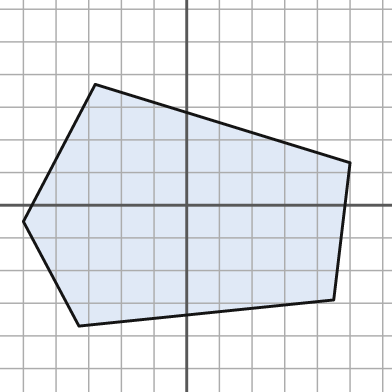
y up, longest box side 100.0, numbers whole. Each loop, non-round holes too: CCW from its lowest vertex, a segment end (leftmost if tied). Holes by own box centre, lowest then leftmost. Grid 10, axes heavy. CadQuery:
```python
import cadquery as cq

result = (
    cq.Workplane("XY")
    .moveTo(-33.0, -37.0)
    .lineTo(45.0, -29.0)
    .lineTo(50.0, 13.0)
    .lineTo(-28.0, 37.0)
    .lineTo(-50.0, -5.0)
    .close()
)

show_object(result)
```